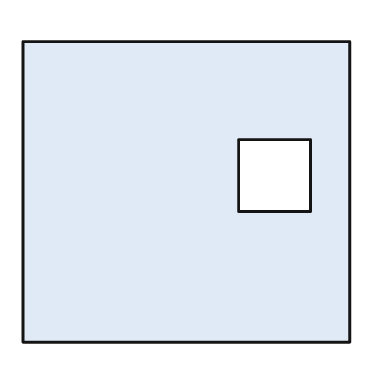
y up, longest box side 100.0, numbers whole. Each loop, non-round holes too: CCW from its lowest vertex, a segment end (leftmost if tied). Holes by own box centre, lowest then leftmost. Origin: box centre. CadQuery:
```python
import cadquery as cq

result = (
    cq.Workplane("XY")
    .moveTo(-50.0, -46.0)
    .lineTo(50.0, -46.0)
    .lineTo(50.0, 46.0)
    .lineTo(-50.0, 46.0)
    .close()
    .moveTo(16.0, -6.0)
    .lineTo(38.0, -6.0)
    .lineTo(38.0, 16.0)
    .lineTo(16.0, 16.0)
    .close()
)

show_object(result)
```